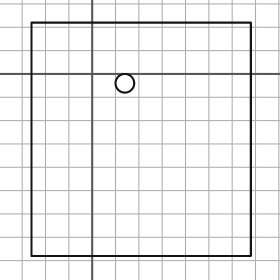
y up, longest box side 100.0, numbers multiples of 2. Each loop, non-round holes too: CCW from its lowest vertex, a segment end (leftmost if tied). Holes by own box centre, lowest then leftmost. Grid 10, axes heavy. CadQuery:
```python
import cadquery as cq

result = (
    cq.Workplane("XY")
    .moveTo(-26.0, -78.0)
    .lineTo(68.0, -78.0)
    .lineTo(68.0, 22.0)
    .lineTo(-26.0, 22.0)
    .close()
    .moveTo(14.0, -4.0)
    .circle(4.0)
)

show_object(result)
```